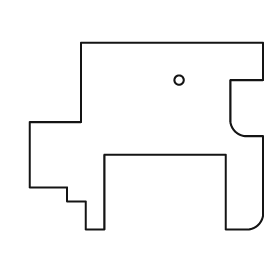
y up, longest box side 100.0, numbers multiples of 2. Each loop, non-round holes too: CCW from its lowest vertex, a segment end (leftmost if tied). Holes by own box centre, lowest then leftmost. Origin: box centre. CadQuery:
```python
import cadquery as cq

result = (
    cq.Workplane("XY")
    .moveTo(-26.0, -40.0)
    .lineTo(-18.0, -40.0)
    .lineTo(-18.0, -8.0)
    .lineTo(34.0, -8.0)
    .lineTo(34.0, -40.0)
    .lineTo(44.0, -40.0)
    .threePointArc((48.0, -38.0), (50.0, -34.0))
    .lineTo(50.0, 0.0)
    .lineTo(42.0, 0.0)
    .threePointArc((38.0, 2.0), (36.0, 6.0))
    .lineTo(36.0, 24.0)
    .lineTo(50.0, 24.0)
    .lineTo(50.0, 40.0)
    .lineTo(-28.0, 40.0)
    .lineTo(-28.0, 6.0)
    .lineTo(-50.0, 6.0)
    .lineTo(-50.0, -22.0)
    .lineTo(-34.0, -22.0)
    .lineTo(-34.0, -28.0)
    .lineTo(-26.0, -28.0)
    .close()
    .moveTo(14.0, 24.0)
    .circle(2.0)
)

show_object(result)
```